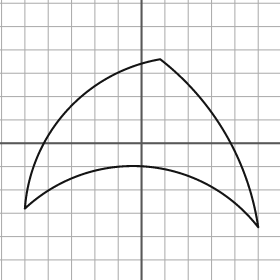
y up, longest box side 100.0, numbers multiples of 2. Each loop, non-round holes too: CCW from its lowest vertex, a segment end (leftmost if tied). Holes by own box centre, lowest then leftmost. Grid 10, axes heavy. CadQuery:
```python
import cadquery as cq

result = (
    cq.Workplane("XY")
    .moveTo(50.0, -36.0)
    .threePointArc((36.0, 4.0), (8.0, 36.0))
    .threePointArc((-32.0, 14.0), (-50.0, -28.0))
    .threePointArc((2.0, -10.0), (50.0, -36.0))
    .close()
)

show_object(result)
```